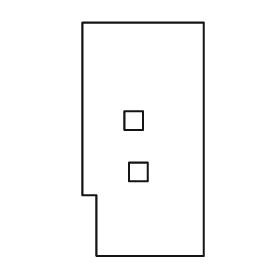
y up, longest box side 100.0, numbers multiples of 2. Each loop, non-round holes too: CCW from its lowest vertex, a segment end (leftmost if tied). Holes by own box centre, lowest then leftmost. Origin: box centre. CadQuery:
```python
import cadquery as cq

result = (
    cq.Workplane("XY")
    .moveTo(-20.0, -50.0)
    .lineTo(26.0, -50.0)
    .lineTo(26.0, 50.0)
    .lineTo(-26.0, 50.0)
    .lineTo(-26.0, -24.0)
    .lineTo(-20.0, -24.0)
    .close()
    .moveTo(-6.0, -18.0)
    .lineTo(2.0, -18.0)
    .lineTo(2.0, -10.0)
    .lineTo(-6.0, -10.0)
    .close()
    .moveTo(-8.0, 4.0)
    .lineTo(0.0, 4.0)
    .lineTo(0.0, 12.0)
    .lineTo(-8.0, 12.0)
    .close()
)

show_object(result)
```